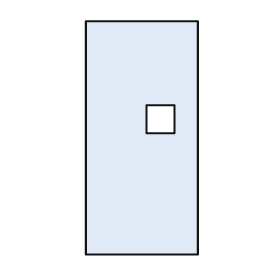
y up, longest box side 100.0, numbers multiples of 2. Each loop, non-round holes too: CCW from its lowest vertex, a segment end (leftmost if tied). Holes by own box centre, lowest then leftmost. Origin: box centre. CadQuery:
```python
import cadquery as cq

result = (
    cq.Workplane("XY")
    .moveTo(-24.0, -50.0)
    .lineTo(24.0, -50.0)
    .lineTo(24.0, 50.0)
    .lineTo(-24.0, 50.0)
    .close()
    .moveTo(2.0, 2.0)
    .lineTo(14.0, 2.0)
    .lineTo(14.0, 14.0)
    .lineTo(2.0, 14.0)
    .close()
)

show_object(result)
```